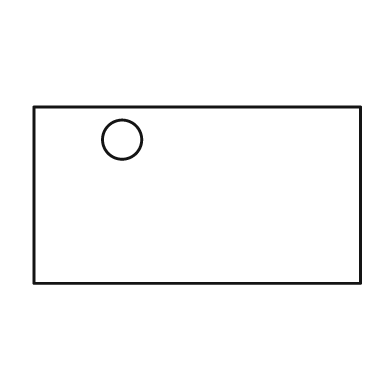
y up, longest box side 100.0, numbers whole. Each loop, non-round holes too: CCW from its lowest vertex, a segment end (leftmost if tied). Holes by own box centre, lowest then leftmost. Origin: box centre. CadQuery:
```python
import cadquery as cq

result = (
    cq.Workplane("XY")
    .moveTo(-50.0, -27.0)
    .lineTo(50.0, -27.0)
    .lineTo(50.0, 27.0)
    .lineTo(-50.0, 27.0)
    .close()
    .moveTo(-23.0, 17.0)
    .circle(6.0)
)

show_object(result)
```